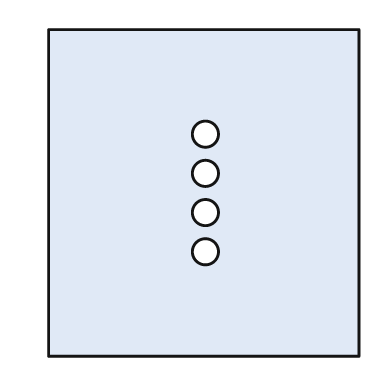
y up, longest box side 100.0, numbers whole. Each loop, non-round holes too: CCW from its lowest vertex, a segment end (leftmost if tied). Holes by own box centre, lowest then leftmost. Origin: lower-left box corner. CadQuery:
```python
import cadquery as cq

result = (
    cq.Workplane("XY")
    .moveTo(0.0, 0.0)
    .lineTo(95.0, 0.0)
    .lineTo(95.0, 100.0)
    .lineTo(0.0, 100.0)
    .close()
    .moveTo(48.0, 32.0)
    .circle(4.0)
    .moveTo(48.0, 44.0)
    .circle(4.0)
    .moveTo(48.0, 56.0)
    .circle(4.0)
    .moveTo(48.0, 68.0)
    .circle(4.0)
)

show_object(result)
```